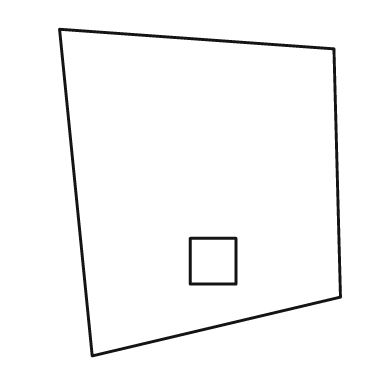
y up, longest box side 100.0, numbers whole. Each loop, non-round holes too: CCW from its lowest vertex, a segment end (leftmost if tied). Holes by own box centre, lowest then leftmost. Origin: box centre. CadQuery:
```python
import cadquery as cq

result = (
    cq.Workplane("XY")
    .moveTo(-33.0, -50.0)
    .lineTo(43.0, -32.0)
    .lineTo(41.0, 44.0)
    .lineTo(-43.0, 50.0)
    .close()
    .moveTo(-3.0, -28.0)
    .lineTo(11.0, -28.0)
    .lineTo(11.0, -14.0)
    .lineTo(-3.0, -14.0)
    .close()
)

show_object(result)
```